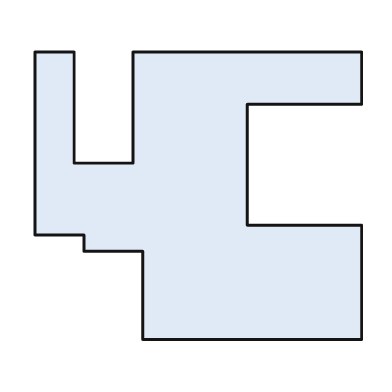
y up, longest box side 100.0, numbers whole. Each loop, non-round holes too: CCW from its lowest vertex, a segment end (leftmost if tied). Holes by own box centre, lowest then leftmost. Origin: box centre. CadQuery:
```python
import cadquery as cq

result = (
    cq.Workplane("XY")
    .moveTo(-17.0, -44.0)
    .lineTo(50.0, -44.0)
    .lineTo(50.0, -9.0)
    .lineTo(15.0, -9.0)
    .lineTo(15.0, 28.0)
    .lineTo(50.0, 28.0)
    .lineTo(50.0, 44.0)
    .lineTo(-20.0, 44.0)
    .lineTo(-20.0, 10.0)
    .lineTo(-38.0, 10.0)
    .lineTo(-38.0, 44.0)
    .lineTo(-50.0, 44.0)
    .lineTo(-50.0, -12.0)
    .lineTo(-35.0, -12.0)
    .lineTo(-35.0, -17.0)
    .lineTo(-17.0, -17.0)
    .close()
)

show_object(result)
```